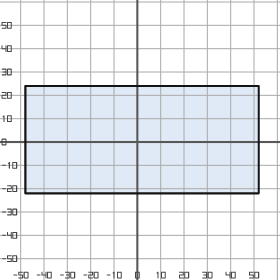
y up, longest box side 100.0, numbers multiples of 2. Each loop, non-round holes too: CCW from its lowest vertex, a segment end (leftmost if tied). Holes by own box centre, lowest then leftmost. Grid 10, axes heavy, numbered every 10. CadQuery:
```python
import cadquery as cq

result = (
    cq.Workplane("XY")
    .moveTo(-48.0, -22.0)
    .lineTo(52.0, -22.0)
    .lineTo(52.0, 24.0)
    .lineTo(-48.0, 24.0)
    .close()
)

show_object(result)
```